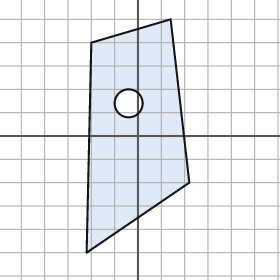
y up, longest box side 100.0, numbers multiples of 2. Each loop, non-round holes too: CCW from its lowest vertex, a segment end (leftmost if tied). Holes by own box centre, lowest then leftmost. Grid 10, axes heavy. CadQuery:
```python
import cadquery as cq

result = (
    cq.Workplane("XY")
    .moveTo(-22.0, -50.0)
    .lineTo(22.0, -20.0)
    .lineTo(14.0, 50.0)
    .lineTo(-20.0, 40.0)
    .close()
    .moveTo(-4.0, 14.0)
    .circle(6.0)
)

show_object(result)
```